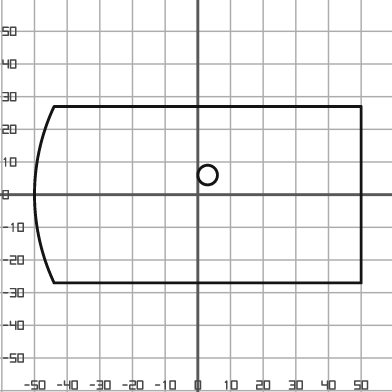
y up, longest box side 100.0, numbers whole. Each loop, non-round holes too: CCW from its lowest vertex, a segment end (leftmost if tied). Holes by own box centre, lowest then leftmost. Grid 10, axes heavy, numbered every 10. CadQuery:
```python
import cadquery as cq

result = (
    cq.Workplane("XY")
    .moveTo(-44.0, -27.0)
    .lineTo(50.0, -27.0)
    .lineTo(50.0, 27.0)
    .lineTo(-44.0, 27.0)
    .threePointArc((-50.0, 0.0), (-44.0, -27.0))
    .close()
    .moveTo(3.0, 6.0)
    .circle(3.0)
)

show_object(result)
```